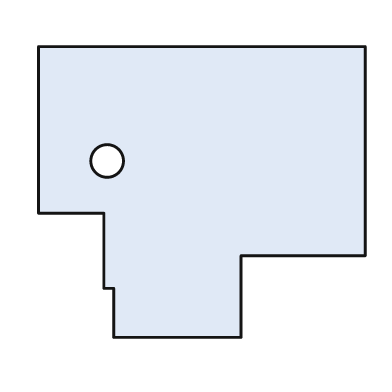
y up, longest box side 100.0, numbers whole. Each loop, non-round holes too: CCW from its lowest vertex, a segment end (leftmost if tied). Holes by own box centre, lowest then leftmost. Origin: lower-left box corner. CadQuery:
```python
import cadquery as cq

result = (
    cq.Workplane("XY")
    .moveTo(23.0, 0.0)
    .lineTo(62.0, 0.0)
    .lineTo(62.0, 25.0)
    .lineTo(100.0, 25.0)
    .lineTo(100.0, 89.0)
    .lineTo(0.0, 89.0)
    .lineTo(0.0, 38.0)
    .lineTo(20.0, 38.0)
    .lineTo(20.0, 15.0)
    .lineTo(23.0, 15.0)
    .close()
    .moveTo(21.0, 54.0)
    .circle(5.0)
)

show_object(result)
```